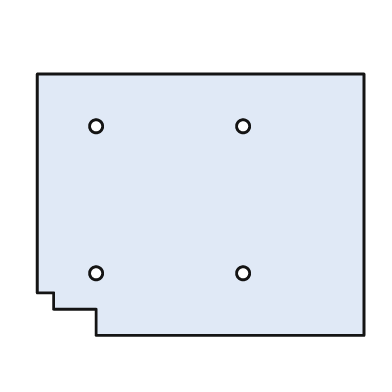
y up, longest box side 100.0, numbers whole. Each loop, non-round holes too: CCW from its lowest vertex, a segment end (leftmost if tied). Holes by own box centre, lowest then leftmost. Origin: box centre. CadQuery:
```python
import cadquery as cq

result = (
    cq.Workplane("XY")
    .moveTo(-32.0, -40.0)
    .lineTo(50.0, -40.0)
    .lineTo(50.0, 40.0)
    .lineTo(-50.0, 40.0)
    .lineTo(-50.0, -27.0)
    .lineTo(-45.0, -27.0)
    .lineTo(-45.0, -32.0)
    .lineTo(-32.0, -32.0)
    .close()
    .moveTo(-32.0, -21.0)
    .circle(2.0)
    .moveTo(13.0, -21.0)
    .circle(2.0)
    .moveTo(-32.0, 24.0)
    .circle(2.0)
    .moveTo(13.0, 24.0)
    .circle(2.0)
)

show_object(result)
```